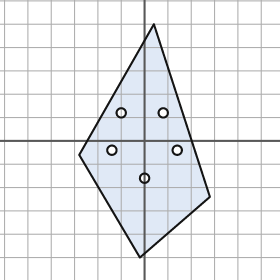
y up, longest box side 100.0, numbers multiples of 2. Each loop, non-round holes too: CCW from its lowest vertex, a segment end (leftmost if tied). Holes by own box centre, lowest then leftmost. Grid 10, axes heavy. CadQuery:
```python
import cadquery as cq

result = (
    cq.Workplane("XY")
    .moveTo(-2.0, -50.0)
    .lineTo(28.0, -24.0)
    .lineTo(4.0, 50.0)
    .lineTo(-28.0, -6.0)
    .close()
    .moveTo(0.0, -16.0)
    .circle(2.0)
    .moveTo(-14.0, -4.0)
    .circle(2.0)
    .moveTo(14.0, -4.0)
    .circle(2.0)
    .moveTo(-10.0, 12.0)
    .circle(2.0)
    .moveTo(8.0, 12.0)
    .circle(2.0)
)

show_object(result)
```